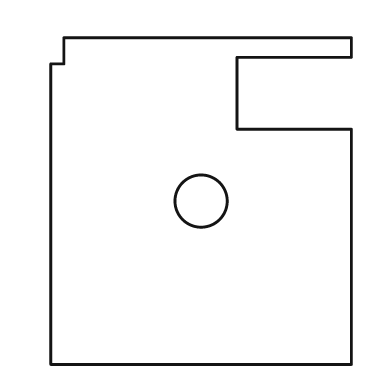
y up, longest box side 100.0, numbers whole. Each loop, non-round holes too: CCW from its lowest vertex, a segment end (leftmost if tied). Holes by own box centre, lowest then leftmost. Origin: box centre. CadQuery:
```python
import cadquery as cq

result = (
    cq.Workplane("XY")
    .moveTo(-46.0, -50.0)
    .lineTo(46.0, -50.0)
    .lineTo(46.0, 22.0)
    .lineTo(11.0, 22.0)
    .lineTo(11.0, 44.0)
    .lineTo(46.0, 44.0)
    .lineTo(46.0, 50.0)
    .lineTo(-42.0, 50.0)
    .lineTo(-42.0, 42.0)
    .lineTo(-46.0, 42.0)
    .close()
    .moveTo(0.0, 0.0)
    .circle(8.0)
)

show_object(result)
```